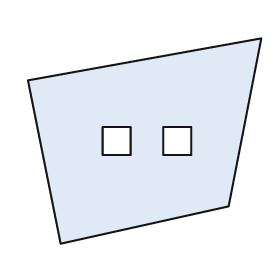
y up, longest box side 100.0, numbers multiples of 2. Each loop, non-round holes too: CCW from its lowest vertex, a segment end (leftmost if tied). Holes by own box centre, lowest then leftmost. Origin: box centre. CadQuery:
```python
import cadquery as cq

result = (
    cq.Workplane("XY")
    .moveTo(-36.0, -44.0)
    .lineTo(36.0, -28.0)
    .lineTo(50.0, 44.0)
    .lineTo(-50.0, 26.0)
    .close()
    .moveTo(-18.0, -6.0)
    .lineTo(-6.0, -6.0)
    .lineTo(-6.0, 6.0)
    .lineTo(-18.0, 6.0)
    .close()
    .moveTo(8.0, -6.0)
    .lineTo(20.0, -6.0)
    .lineTo(20.0, 6.0)
    .lineTo(8.0, 6.0)
    .close()
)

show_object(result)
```